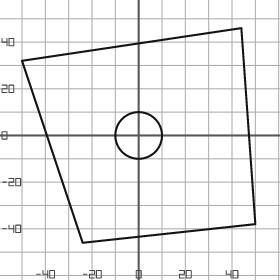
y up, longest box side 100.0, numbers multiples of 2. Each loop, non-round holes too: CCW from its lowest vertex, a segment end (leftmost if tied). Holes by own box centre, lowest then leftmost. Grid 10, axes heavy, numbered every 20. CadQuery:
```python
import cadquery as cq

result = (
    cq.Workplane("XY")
    .moveTo(-24.0, -46.0)
    .lineTo(50.0, -38.0)
    .lineTo(44.0, 46.0)
    .lineTo(-50.0, 32.0)
    .close()
    .moveTo(0.0, 0.0)
    .circle(10.0)
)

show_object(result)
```